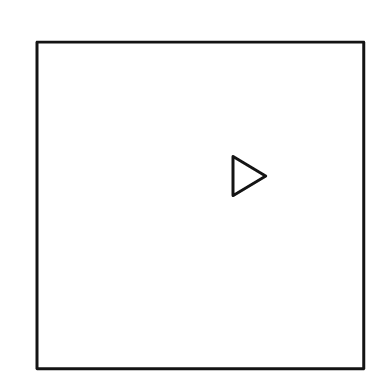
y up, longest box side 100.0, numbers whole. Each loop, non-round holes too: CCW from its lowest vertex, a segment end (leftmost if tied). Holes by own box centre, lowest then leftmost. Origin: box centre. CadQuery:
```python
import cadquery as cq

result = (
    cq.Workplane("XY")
    .moveTo(-50.0, -50.0)
    .lineTo(50.0, -50.0)
    .lineTo(50.0, 50.0)
    .lineTo(-50.0, 50.0)
    .close()
    .moveTo(10.0, 3.0)
    .lineTo(20.0, 9.0)
    .lineTo(10.0, 15.0)
    .close()
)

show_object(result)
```